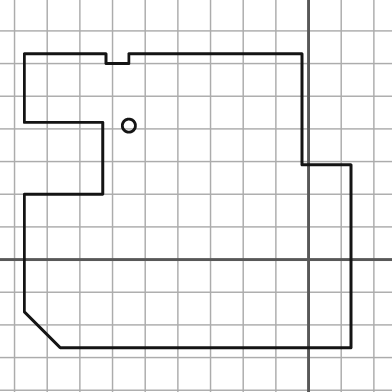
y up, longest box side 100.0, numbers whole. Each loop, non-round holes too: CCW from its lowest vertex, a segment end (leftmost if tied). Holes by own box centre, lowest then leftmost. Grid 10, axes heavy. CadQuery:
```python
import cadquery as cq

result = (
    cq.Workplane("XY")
    .moveTo(-76.0, -27.0)
    .lineTo(13.0, -27.0)
    .lineTo(13.0, 29.0)
    .lineTo(-2.0, 29.0)
    .lineTo(-2.0, 63.0)
    .lineTo(-55.0, 63.0)
    .lineTo(-55.0, 60.0)
    .lineTo(-62.0, 60.0)
    .lineTo(-62.0, 63.0)
    .lineTo(-87.0, 63.0)
    .lineTo(-87.0, 42.0)
    .lineTo(-63.0, 42.0)
    .lineTo(-63.0, 20.0)
    .lineTo(-87.0, 20.0)
    .lineTo(-87.0, -16.0)
    .close()
    .moveTo(-55.0, 41.0)
    .circle(2.0)
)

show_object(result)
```